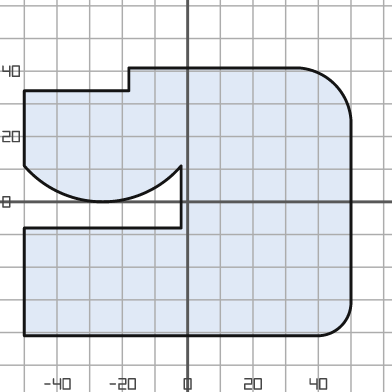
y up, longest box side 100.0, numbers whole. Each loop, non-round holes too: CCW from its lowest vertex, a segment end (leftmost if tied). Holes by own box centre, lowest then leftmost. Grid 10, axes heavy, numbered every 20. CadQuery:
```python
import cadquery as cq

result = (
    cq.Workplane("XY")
    .moveTo(-50.0, -41.0)
    .lineTo(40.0, -41.0)
    .threePointArc((47.0, -38.0), (50.0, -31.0))
    .lineTo(50.0, 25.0)
    .threePointArc((45.0, 36.0), (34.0, 41.0))
    .lineTo(-18.0, 41.0)
    .lineTo(-18.0, 34.0)
    .lineTo(-50.0, 34.0)
    .lineTo(-50.0, 11.0)
    .threePointArc((-26.0, 0.0), (-2.0, 11.0))
    .lineTo(-2.0, -8.0)
    .lineTo(-50.0, -8.0)
    .close()
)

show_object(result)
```